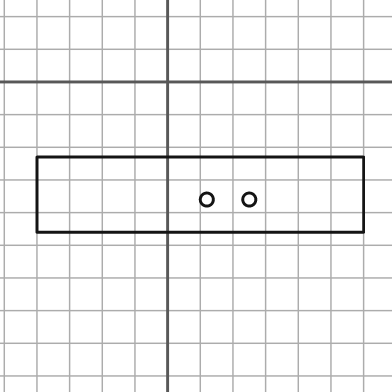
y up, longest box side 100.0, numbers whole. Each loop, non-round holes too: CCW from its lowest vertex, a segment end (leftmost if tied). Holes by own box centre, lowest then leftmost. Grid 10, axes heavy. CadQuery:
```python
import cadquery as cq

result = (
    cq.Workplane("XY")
    .moveTo(-40.0, -46.0)
    .lineTo(60.0, -46.0)
    .lineTo(60.0, -23.0)
    .lineTo(-40.0, -23.0)
    .close()
    .moveTo(12.0, -36.0)
    .circle(2.0)
    .moveTo(25.0, -36.0)
    .circle(2.0)
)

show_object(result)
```